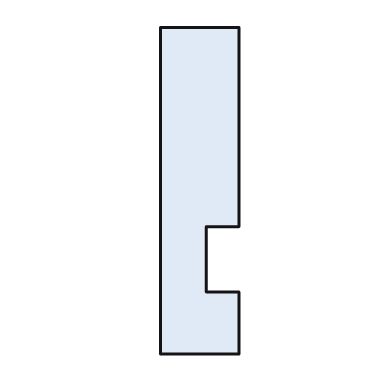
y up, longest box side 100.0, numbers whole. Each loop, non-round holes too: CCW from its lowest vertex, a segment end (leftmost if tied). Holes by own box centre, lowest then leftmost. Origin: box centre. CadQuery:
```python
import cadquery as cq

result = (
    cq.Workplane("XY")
    .moveTo(-12.0, -50.0)
    .lineTo(12.0, -50.0)
    .lineTo(12.0, -31.0)
    .lineTo(2.0, -31.0)
    .lineTo(2.0, -11.0)
    .lineTo(12.0, -11.0)
    .lineTo(12.0, 50.0)
    .lineTo(-12.0, 50.0)
    .close()
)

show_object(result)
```